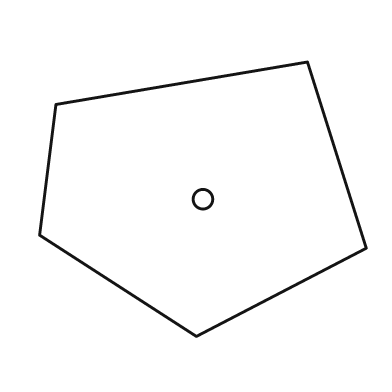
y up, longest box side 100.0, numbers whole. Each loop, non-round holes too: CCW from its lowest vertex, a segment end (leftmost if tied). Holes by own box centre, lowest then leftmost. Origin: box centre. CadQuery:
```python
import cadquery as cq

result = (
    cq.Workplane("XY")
    .moveTo(-2.0, -42.0)
    .lineTo(50.0, -15.0)
    .lineTo(32.0, 42.0)
    .lineTo(-45.0, 29.0)
    .lineTo(-50.0, -11.0)
    .close()
    .moveTo(0.0, 0.0)
    .circle(3.0)
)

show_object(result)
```